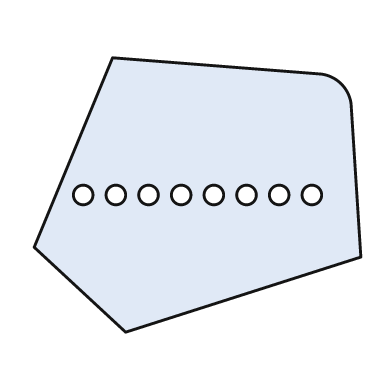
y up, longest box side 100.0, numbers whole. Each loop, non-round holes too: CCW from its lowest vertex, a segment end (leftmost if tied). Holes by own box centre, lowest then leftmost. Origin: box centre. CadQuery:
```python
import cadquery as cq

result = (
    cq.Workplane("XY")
    .moveTo(-22.0, -42.0)
    .lineTo(50.0, -19.0)
    .lineTo(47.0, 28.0)
    .threePointArc((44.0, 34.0), (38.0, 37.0))
    .lineTo(-26.0, 42.0)
    .lineTo(-50.0, -16.0)
    .close()
    .moveTo(-35.0, 0.0)
    .circle(3.0)
    .moveTo(-25.0, 0.0)
    .circle(3.0)
    .moveTo(-15.0, 0.0)
    .circle(3.0)
    .moveTo(-5.0, 0.0)
    .circle(3.0)
    .moveTo(5.0, 0.0)
    .circle(3.0)
    .moveTo(15.0, 0.0)
    .circle(3.0)
    .moveTo(25.0, 0.0)
    .circle(3.0)
    .moveTo(35.0, 0.0)
    .circle(3.0)
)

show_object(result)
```